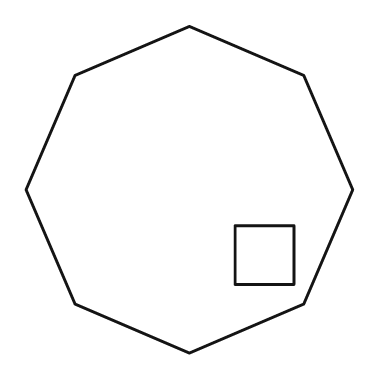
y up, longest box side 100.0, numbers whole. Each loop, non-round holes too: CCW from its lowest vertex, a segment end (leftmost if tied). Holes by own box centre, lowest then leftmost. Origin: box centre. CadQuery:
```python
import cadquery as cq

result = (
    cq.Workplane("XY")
    .moveTo(0.0, -50.0)
    .lineTo(35.0, -35.0)
    .lineTo(50.0, 0.0)
    .lineTo(35.0, 35.0)
    .lineTo(0.0, 50.0)
    .lineTo(-35.0, 35.0)
    .lineTo(-50.0, 0.0)
    .lineTo(-35.0, -35.0)
    .close()
    .moveTo(14.0, -29.0)
    .lineTo(32.0, -29.0)
    .lineTo(32.0, -11.0)
    .lineTo(14.0, -11.0)
    .close()
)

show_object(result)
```